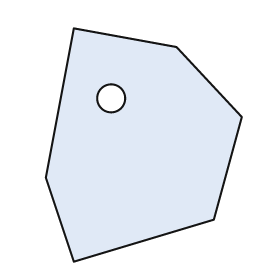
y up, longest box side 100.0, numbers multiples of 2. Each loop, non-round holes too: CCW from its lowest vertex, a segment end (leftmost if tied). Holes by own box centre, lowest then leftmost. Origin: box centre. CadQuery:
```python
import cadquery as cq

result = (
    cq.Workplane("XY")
    .moveTo(-30.0, -50.0)
    .lineTo(30.0, -32.0)
    .lineTo(42.0, 12.0)
    .lineTo(14.0, 42.0)
    .lineTo(-30.0, 50.0)
    .lineTo(-42.0, -14.0)
    .close()
    .moveTo(-14.0, 20.0)
    .circle(6.0)
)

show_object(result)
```